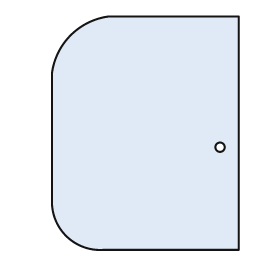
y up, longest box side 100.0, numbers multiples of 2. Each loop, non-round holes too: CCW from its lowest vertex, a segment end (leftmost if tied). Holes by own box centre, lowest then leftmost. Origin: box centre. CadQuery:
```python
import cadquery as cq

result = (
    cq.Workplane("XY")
    .moveTo(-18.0, -50.0)
    .lineTo(40.0, -50.0)
    .lineTo(40.0, 50.0)
    .lineTo(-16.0, 50.0)
    .threePointArc((-32.0, 42.0), (-40.0, 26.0))
    .lineTo(-40.0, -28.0)
    .threePointArc((-34.0, -44.0), (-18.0, -50.0))
    .close()
    .moveTo(32.0, -6.0)
    .circle(2.0)
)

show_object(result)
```